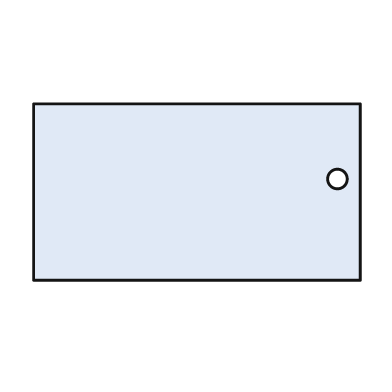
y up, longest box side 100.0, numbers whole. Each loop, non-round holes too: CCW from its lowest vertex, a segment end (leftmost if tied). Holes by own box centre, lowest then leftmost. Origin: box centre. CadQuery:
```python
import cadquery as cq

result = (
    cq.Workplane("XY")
    .moveTo(-50.0, -27.0)
    .lineTo(50.0, -27.0)
    .lineTo(50.0, 27.0)
    .lineTo(-50.0, 27.0)
    .close()
    .moveTo(43.0, 4.0)
    .circle(3.0)
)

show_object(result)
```